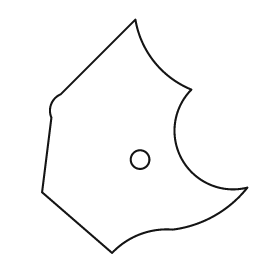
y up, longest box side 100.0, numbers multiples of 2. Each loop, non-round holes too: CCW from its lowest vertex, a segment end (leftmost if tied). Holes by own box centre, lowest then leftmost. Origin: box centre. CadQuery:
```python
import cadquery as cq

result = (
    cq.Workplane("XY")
    .moveTo(-14.0, -50.0)
    .threePointArc((-2.0, -42.0), (12.0, -40.0))
    .threePointArc((30.0, -34.0), (44.0, -22.0))
    .threePointArc((16.0, -10.0), (20.0, 20.0))
    .threePointArc((4.0, 32.0), (-4.0, 50.0))
    .lineTo(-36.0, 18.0)
    .threePointArc((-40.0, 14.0), (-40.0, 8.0))
    .lineTo(-44.0, -24.0)
    .close()
    .moveTo(-2.0, -10.0)
    .circle(4.0)
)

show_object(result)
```